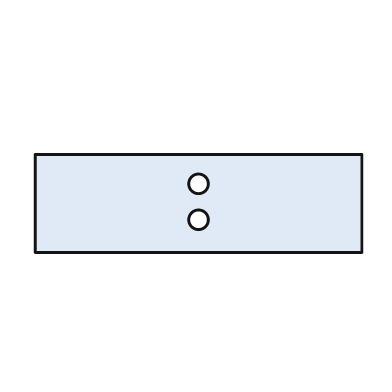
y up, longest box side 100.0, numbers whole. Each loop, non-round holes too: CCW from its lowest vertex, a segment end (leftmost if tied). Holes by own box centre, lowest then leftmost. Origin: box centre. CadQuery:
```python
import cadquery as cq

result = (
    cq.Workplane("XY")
    .moveTo(-50.0, -15.0)
    .lineTo(50.0, -15.0)
    .lineTo(50.0, 15.0)
    .lineTo(-50.0, 15.0)
    .close()
    .moveTo(0.0, -5.0)
    .circle(3.0)
    .moveTo(0.0, 6.0)
    .circle(3.0)
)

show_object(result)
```